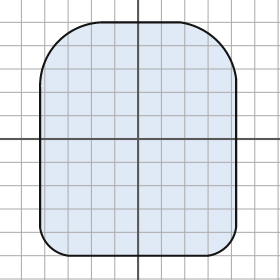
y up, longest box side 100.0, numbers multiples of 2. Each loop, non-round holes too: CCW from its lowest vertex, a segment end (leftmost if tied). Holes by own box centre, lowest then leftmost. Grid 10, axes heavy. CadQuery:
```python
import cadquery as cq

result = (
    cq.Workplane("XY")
    .moveTo(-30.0, -50.0)
    .lineTo(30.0, -50.0)
    .threePointArc((38.0, -46.0), (42.0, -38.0))
    .lineTo(42.0, 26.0)
    .threePointArc((34.0, 42.0), (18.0, 50.0))
    .lineTo(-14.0, 50.0)
    .threePointArc((-34.0, 42.0), (-42.0, 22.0))
    .lineTo(-42.0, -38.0)
    .threePointArc((-38.0, -46.0), (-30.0, -50.0))
    .close()
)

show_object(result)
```